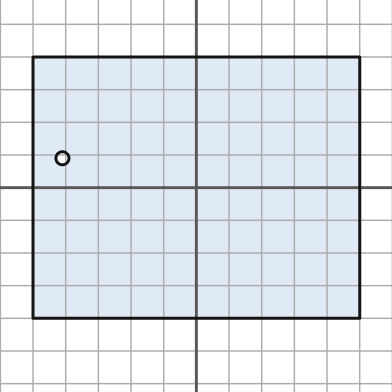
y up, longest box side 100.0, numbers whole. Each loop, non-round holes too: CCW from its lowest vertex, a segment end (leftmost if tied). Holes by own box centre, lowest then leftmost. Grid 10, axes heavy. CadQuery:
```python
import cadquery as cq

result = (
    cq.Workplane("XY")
    .moveTo(-50.0, -40.0)
    .lineTo(50.0, -40.0)
    .lineTo(50.0, 40.0)
    .lineTo(-50.0, 40.0)
    .close()
    .moveTo(-41.0, 9.0)
    .circle(2.0)
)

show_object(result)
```